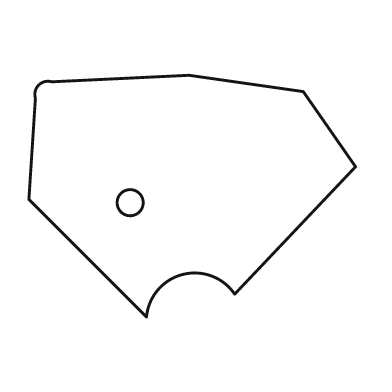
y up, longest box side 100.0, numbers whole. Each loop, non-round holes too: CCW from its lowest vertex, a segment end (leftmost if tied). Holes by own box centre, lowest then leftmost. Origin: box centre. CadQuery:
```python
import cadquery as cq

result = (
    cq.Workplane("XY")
    .moveTo(-14.0, -37.0)
    .threePointArc((-3.0, -24.0), (13.0, -30.0))
    .lineTo(50.0, 9.0)
    .lineTo(34.0, 32.0)
    .lineTo(-1.0, 37.0)
    .lineTo(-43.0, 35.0)
    .threePointArc((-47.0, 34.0), (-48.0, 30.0))
    .lineTo(-50.0, -1.0)
    .close()
    .moveTo(-19.0, -2.0)
    .circle(4.0)
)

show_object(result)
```